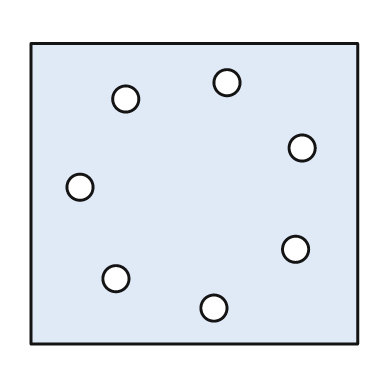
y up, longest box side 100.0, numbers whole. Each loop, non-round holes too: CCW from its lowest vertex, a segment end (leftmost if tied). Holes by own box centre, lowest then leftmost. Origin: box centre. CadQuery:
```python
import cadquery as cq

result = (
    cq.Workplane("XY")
    .moveTo(-50.0, -46.0)
    .lineTo(50.0, -46.0)
    .lineTo(50.0, 46.0)
    .lineTo(-50.0, 46.0)
    .close()
    .moveTo(6.0, -35.0)
    .circle(4.0)
    .moveTo(-24.0, -26.0)
    .circle(4.0)
    .moveTo(31.0, -17.0)
    .circle(4.0)
    .moveTo(-35.0, 2.0)
    .circle(4.0)
    .moveTo(33.0, 14.0)
    .circle(4.0)
    .moveTo(-21.0, 29.0)
    .circle(4.0)
    .moveTo(10.0, 34.0)
    .circle(4.0)
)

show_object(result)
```